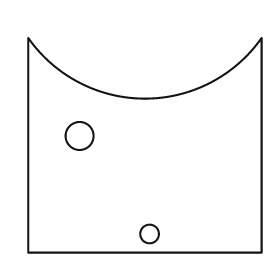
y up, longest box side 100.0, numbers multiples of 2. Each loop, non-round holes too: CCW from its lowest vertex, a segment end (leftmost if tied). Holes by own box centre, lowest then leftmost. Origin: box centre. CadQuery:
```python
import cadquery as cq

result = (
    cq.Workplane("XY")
    .moveTo(-50.0, -46.0)
    .lineTo(50.0, -46.0)
    .lineTo(50.0, 46.0)
    .threePointArc((0.0, 20.0), (-50.0, 46.0))
    .close()
    .moveTo(2.0, -38.0)
    .circle(4.0)
    .moveTo(-28.0, 4.0)
    .circle(6.0)
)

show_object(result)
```